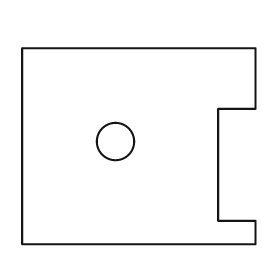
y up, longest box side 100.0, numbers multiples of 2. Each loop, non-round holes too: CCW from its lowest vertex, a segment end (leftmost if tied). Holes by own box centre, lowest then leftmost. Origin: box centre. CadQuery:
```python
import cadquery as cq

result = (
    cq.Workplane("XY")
    .moveTo(-50.0, -42.0)
    .lineTo(50.0, -42.0)
    .lineTo(50.0, -32.0)
    .lineTo(34.0, -32.0)
    .lineTo(34.0, 16.0)
    .lineTo(50.0, 16.0)
    .lineTo(50.0, 42.0)
    .lineTo(-50.0, 42.0)
    .close()
    .moveTo(-10.0, 2.0)
    .circle(8.0)
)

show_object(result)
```